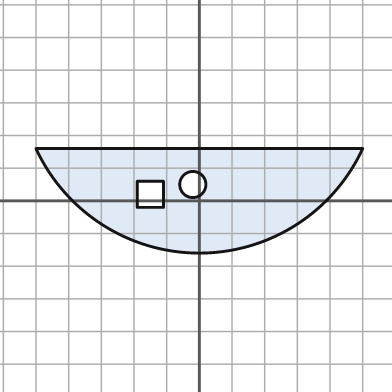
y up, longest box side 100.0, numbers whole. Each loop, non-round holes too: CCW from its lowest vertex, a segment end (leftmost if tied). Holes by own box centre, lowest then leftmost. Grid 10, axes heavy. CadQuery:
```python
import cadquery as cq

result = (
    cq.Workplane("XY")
    .moveTo(-50.0, 16.0)
    .threePointArc((0.0, -16.0), (50.0, 16.0))
    .close()
    .moveTo(-19.0, -2.0)
    .lineTo(-11.0, -2.0)
    .lineTo(-11.0, 6.0)
    .lineTo(-19.0, 6.0)
    .close()
    .moveTo(-2.0, 5.0)
    .circle(4.0)
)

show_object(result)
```